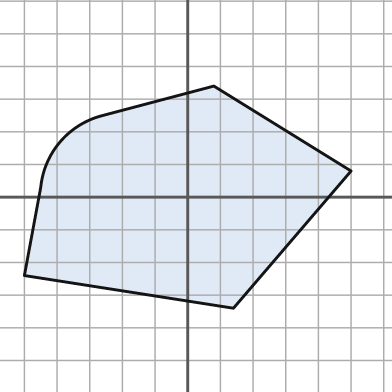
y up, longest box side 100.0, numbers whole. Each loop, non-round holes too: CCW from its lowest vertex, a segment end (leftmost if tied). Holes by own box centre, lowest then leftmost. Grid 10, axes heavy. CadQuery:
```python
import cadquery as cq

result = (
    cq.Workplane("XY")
    .moveTo(14.0, -34.0)
    .lineTo(50.0, 8.0)
    .lineTo(8.0, 34.0)
    .lineTo(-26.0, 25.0)
    .threePointArc((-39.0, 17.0), (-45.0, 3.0))
    .lineTo(-50.0, -24.0)
    .close()
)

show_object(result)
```